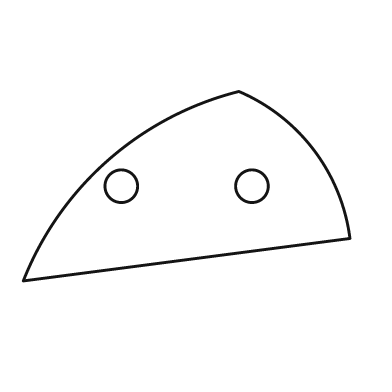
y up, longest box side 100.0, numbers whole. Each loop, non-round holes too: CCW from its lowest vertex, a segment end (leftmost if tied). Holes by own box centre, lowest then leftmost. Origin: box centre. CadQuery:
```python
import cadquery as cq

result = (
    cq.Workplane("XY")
    .moveTo(-50.0, -29.0)
    .lineTo(50.0, -16.0)
    .threePointArc((39.0, 11.0), (16.0, 29.0))
    .threePointArc((-24.0, 8.0), (-50.0, -29.0))
    .close()
    .moveTo(-20.0, 0.0)
    .circle(5.0)
    .moveTo(20.0, 0.0)
    .circle(5.0)
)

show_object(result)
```